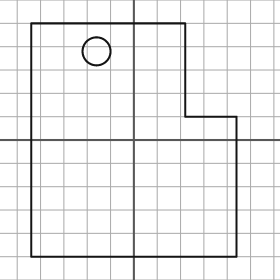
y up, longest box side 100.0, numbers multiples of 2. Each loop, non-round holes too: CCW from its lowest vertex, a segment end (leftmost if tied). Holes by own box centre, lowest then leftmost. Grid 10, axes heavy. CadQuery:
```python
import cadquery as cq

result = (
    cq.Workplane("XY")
    .moveTo(-44.0, -50.0)
    .lineTo(44.0, -50.0)
    .lineTo(44.0, 10.0)
    .lineTo(22.0, 10.0)
    .lineTo(22.0, 50.0)
    .lineTo(-44.0, 50.0)
    .close()
    .moveTo(-16.0, 38.0)
    .circle(6.0)
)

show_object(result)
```